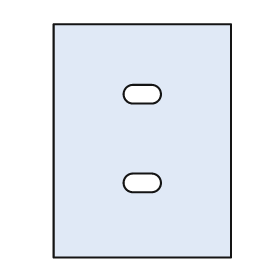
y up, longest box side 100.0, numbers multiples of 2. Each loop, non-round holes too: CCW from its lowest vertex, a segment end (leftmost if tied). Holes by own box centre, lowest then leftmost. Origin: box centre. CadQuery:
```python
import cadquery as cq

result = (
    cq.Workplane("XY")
    .moveTo(-38.0, -50.0)
    .lineTo(38.0, -50.0)
    .lineTo(38.0, 50.0)
    .lineTo(-38.0, 50.0)
    .close()
    .moveTo(-4.0, -22.0)
    .lineTo(4.0, -22.0)
    .threePointArc((8.0, -18.0), (4.0, -14.0))
    .lineTo(-4.0, -14.0)
    .threePointArc((-8.0, -18.0), (-4.0, -22.0))
    .close()
    .moveTo(-4.0, 16.0)
    .lineTo(4.0, 16.0)
    .threePointArc((8.0, 20.0), (4.0, 24.0))
    .lineTo(-4.0, 24.0)
    .threePointArc((-8.0, 20.0), (-4.0, 16.0))
    .close()
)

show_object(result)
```